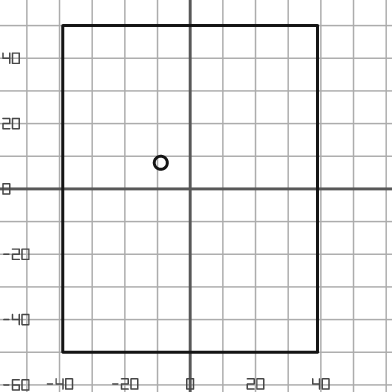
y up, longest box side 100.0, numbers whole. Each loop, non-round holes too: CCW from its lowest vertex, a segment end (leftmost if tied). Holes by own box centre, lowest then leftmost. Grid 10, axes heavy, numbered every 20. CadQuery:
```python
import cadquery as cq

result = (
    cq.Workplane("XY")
    .moveTo(-39.0, -50.0)
    .lineTo(39.0, -50.0)
    .lineTo(39.0, 50.0)
    .lineTo(-39.0, 50.0)
    .close()
    .moveTo(-9.0, 8.0)
    .circle(2.0)
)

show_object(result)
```